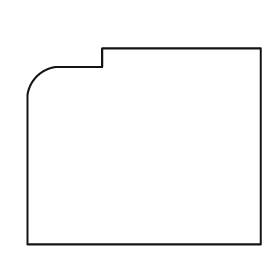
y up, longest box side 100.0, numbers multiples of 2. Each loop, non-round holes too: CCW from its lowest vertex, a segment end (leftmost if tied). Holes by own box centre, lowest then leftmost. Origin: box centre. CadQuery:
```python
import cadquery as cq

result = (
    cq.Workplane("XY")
    .moveTo(-50.0, -42.0)
    .lineTo(50.0, -42.0)
    .lineTo(50.0, 42.0)
    .lineTo(-18.0, 42.0)
    .lineTo(-18.0, 34.0)
    .lineTo(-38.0, 34.0)
    .threePointArc((-46.0, 30.0), (-50.0, 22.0))
    .close()
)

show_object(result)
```